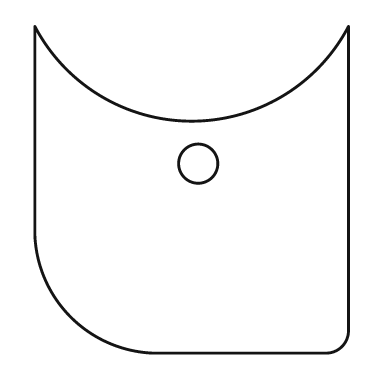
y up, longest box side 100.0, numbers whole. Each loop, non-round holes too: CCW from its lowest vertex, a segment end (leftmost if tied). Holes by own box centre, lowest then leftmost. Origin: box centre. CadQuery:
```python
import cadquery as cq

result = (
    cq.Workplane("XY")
    .moveTo(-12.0, -50.0)
    .lineTo(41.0, -50.0)
    .threePointArc((46.0, -48.0), (48.0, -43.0))
    .lineTo(48.0, 50.0)
    .threePointArc((0.0, 21.0), (-48.0, 50.0))
    .lineTo(-48.0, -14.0)
    .threePointArc((-37.0, -39.0), (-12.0, -50.0))
    .close()
    .moveTo(2.0, 8.0)
    .circle(6.0)
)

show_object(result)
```